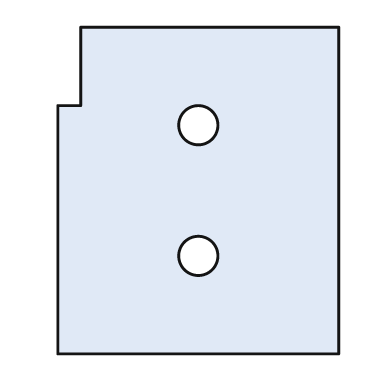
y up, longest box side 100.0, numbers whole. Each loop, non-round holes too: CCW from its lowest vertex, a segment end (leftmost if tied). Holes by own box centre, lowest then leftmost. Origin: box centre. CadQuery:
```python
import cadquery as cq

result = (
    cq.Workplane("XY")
    .moveTo(-43.0, -50.0)
    .lineTo(43.0, -50.0)
    .lineTo(43.0, 50.0)
    .lineTo(-36.0, 50.0)
    .lineTo(-36.0, 26.0)
    .lineTo(-43.0, 26.0)
    .close()
    .moveTo(0.0, -20.0)
    .circle(6.0)
    .moveTo(0.0, 20.0)
    .circle(6.0)
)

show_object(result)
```